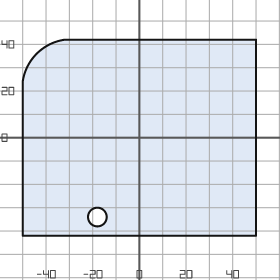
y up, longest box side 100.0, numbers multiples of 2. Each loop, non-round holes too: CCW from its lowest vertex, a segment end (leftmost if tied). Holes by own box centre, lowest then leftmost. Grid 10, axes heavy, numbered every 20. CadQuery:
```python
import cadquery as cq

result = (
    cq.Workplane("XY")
    .moveTo(-50.0, -42.0)
    .lineTo(50.0, -42.0)
    .lineTo(50.0, 42.0)
    .lineTo(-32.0, 42.0)
    .threePointArc((-44.0, 36.0), (-50.0, 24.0))
    .close()
    .moveTo(-18.0, -34.0)
    .circle(4.0)
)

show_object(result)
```